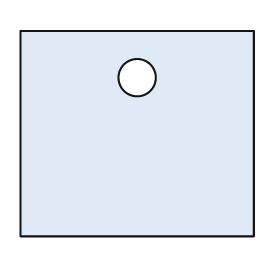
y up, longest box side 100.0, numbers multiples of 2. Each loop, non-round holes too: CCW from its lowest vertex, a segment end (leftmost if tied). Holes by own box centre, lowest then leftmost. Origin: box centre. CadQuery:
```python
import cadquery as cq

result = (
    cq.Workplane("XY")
    .moveTo(-50.0, -44.0)
    .lineTo(50.0, -44.0)
    .lineTo(50.0, 44.0)
    .lineTo(-50.0, 44.0)
    .close()
    .moveTo(0.0, 24.0)
    .circle(8.0)
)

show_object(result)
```